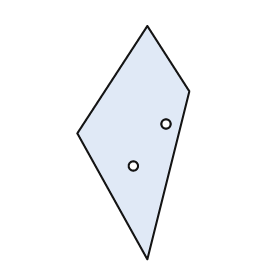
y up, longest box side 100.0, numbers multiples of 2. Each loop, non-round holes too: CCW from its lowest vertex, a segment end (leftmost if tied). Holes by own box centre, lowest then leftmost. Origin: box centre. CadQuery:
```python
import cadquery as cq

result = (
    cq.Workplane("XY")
    .moveTo(6.0, -50.0)
    .lineTo(24.0, 22.0)
    .lineTo(6.0, 50.0)
    .lineTo(-24.0, 4.0)
    .close()
    .moveTo(0.0, -10.0)
    .circle(2.0)
    .moveTo(14.0, 8.0)
    .circle(2.0)
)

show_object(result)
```